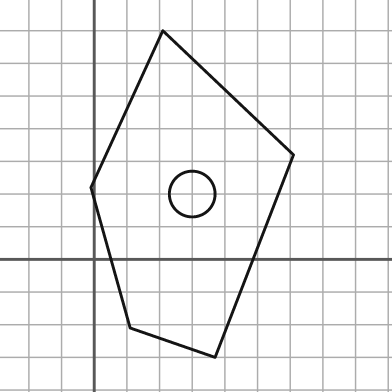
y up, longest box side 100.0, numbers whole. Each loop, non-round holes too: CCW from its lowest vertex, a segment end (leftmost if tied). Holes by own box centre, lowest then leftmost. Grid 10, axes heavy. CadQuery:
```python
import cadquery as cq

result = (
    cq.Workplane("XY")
    .moveTo(37.0, -30.0)
    .lineTo(61.0, 32.0)
    .lineTo(21.0, 70.0)
    .lineTo(-1.0, 22.0)
    .lineTo(11.0, -21.0)
    .close()
    .moveTo(30.0, 20.0)
    .circle(7.0)
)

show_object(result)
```